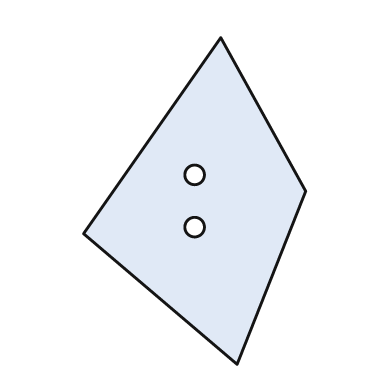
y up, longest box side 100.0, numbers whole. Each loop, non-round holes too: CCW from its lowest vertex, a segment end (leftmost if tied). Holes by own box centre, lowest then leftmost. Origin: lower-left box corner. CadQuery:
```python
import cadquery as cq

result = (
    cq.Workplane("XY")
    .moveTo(47.0, 0.0)
    .lineTo(68.0, 53.0)
    .lineTo(42.0, 100.0)
    .lineTo(0.0, 40.0)
    .close()
    .moveTo(34.0, 42.0)
    .circle(3.0)
    .moveTo(34.0, 58.0)
    .circle(3.0)
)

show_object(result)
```